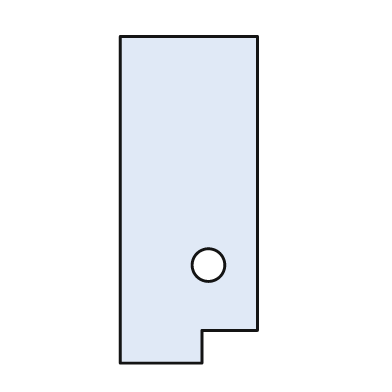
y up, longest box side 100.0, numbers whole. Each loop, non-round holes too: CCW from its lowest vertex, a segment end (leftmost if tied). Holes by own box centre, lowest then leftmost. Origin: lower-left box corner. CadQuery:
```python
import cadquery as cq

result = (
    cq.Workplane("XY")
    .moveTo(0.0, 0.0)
    .lineTo(25.0, 0.0)
    .lineTo(25.0, 10.0)
    .lineTo(42.0, 10.0)
    .lineTo(42.0, 100.0)
    .lineTo(0.0, 100.0)
    .close()
    .moveTo(27.0, 30.0)
    .circle(5.0)
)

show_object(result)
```